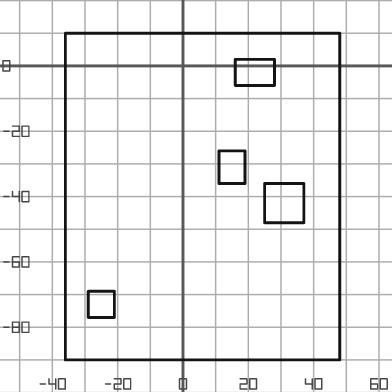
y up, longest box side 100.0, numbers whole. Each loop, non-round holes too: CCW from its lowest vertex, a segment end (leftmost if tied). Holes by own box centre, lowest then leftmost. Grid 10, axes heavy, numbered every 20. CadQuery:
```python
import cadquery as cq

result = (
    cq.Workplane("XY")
    .moveTo(-36.0, -90.0)
    .lineTo(48.0, -90.0)
    .lineTo(48.0, 10.0)
    .lineTo(-36.0, 10.0)
    .close()
    .moveTo(-29.0, -77.0)
    .lineTo(-21.0, -77.0)
    .lineTo(-21.0, -69.0)
    .lineTo(-29.0, -69.0)
    .close()
    .moveTo(25.0, -48.0)
    .lineTo(37.0, -48.0)
    .lineTo(37.0, -36.0)
    .lineTo(25.0, -36.0)
    .close()
    .moveTo(11.0, -36.0)
    .lineTo(19.0, -36.0)
    .lineTo(19.0, -26.0)
    .lineTo(11.0, -26.0)
    .close()
    .moveTo(16.0, -6.0)
    .lineTo(28.0, -6.0)
    .lineTo(28.0, 2.0)
    .lineTo(16.0, 2.0)
    .close()
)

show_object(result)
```